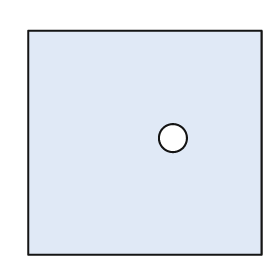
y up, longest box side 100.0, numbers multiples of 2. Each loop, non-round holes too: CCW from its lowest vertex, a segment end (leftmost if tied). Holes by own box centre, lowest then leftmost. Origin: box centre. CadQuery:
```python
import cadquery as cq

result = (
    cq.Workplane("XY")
    .moveTo(-50.0, -48.0)
    .lineTo(50.0, -48.0)
    .lineTo(50.0, 48.0)
    .lineTo(-50.0, 48.0)
    .close()
    .moveTo(12.0, 2.0)
    .circle(6.0)
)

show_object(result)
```